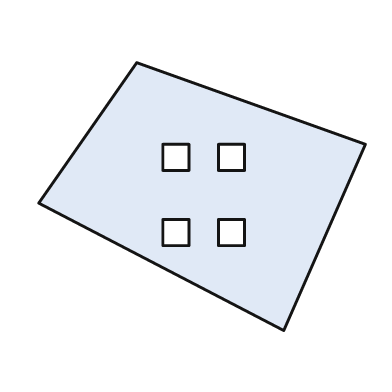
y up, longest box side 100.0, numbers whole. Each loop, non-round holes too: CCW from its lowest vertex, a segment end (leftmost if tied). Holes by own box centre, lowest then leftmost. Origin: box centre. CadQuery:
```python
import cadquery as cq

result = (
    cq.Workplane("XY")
    .moveTo(25.0, -41.0)
    .lineTo(50.0, 16.0)
    .lineTo(-20.0, 41.0)
    .lineTo(-50.0, -2.0)
    .close()
    .moveTo(-12.0, -15.0)
    .lineTo(-4.0, -15.0)
    .lineTo(-4.0, -7.0)
    .lineTo(-12.0, -7.0)
    .close()
    .moveTo(5.0, -15.0)
    .lineTo(13.0, -15.0)
    .lineTo(13.0, -7.0)
    .lineTo(5.0, -7.0)
    .close()
    .moveTo(-12.0, 8.0)
    .lineTo(-4.0, 8.0)
    .lineTo(-4.0, 16.0)
    .lineTo(-12.0, 16.0)
    .close()
    .moveTo(5.0, 8.0)
    .lineTo(13.0, 8.0)
    .lineTo(13.0, 16.0)
    .lineTo(5.0, 16.0)
    .close()
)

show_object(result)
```